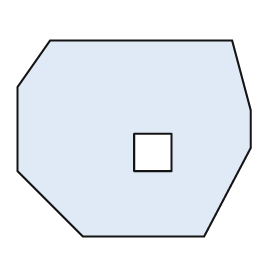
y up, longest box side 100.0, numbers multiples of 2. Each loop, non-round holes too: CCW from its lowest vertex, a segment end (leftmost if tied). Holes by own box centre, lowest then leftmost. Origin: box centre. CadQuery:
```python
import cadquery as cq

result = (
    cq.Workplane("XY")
    .moveTo(-22.0, -42.0)
    .lineTo(30.0, -42.0)
    .lineTo(50.0, -4.0)
    .lineTo(50.0, 12.0)
    .lineTo(42.0, 42.0)
    .lineTo(-36.0, 42.0)
    .lineTo(-50.0, 22.0)
    .lineTo(-50.0, -14.0)
    .close()
    .moveTo(0.0, -14.0)
    .lineTo(16.0, -14.0)
    .lineTo(16.0, 2.0)
    .lineTo(0.0, 2.0)
    .close()
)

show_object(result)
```